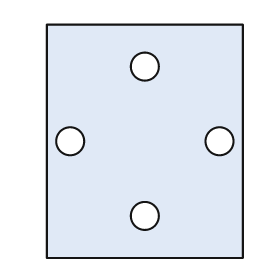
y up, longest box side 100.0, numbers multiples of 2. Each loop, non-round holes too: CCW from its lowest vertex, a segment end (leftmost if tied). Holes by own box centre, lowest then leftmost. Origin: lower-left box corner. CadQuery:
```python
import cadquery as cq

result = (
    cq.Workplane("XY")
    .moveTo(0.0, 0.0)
    .lineTo(84.0, 0.0)
    .lineTo(84.0, 100.0)
    .lineTo(0.0, 100.0)
    .close()
    .moveTo(42.0, 18.0)
    .circle(6.0)
    .moveTo(10.0, 50.0)
    .circle(6.0)
    .moveTo(74.0, 50.0)
    .circle(6.0)
    .moveTo(42.0, 82.0)
    .circle(6.0)
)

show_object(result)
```